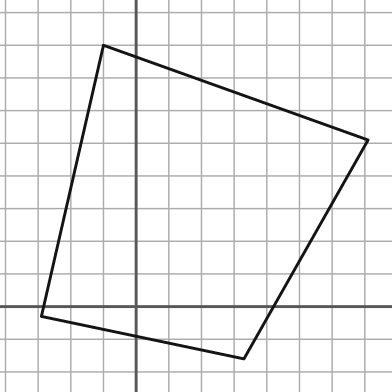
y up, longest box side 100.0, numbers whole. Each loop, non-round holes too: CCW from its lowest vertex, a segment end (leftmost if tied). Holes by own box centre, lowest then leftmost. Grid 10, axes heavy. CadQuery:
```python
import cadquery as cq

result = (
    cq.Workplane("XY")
    .moveTo(33.0, -16.0)
    .lineTo(71.0, 51.0)
    .lineTo(-10.0, 80.0)
    .lineTo(-29.0, -3.0)
    .close()
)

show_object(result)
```